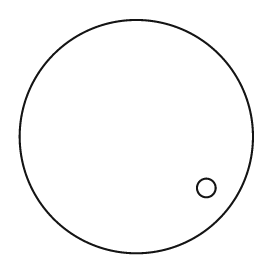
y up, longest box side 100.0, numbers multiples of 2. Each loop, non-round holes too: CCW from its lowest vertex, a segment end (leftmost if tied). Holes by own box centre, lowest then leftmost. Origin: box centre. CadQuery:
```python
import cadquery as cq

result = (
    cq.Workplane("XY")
    .moveTo(0.0, 0.0)
    .circle(50.0)
    .moveTo(30.0, -22.0)
    .circle(4.0)
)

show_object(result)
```